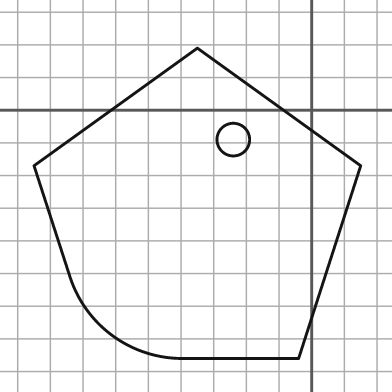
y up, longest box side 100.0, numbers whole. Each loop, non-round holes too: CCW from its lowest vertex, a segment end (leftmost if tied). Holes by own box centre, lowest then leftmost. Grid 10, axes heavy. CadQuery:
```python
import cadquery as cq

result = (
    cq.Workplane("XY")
    .moveTo(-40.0, -76.0)
    .lineTo(-4.0, -76.0)
    .lineTo(15.0, -17.0)
    .lineTo(-35.0, 19.0)
    .lineTo(-85.0, -17.0)
    .lineTo(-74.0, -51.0)
    .threePointArc((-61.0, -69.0), (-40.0, -76.0))
    .close()
    .moveTo(-24.0, -9.0)
    .circle(5.0)
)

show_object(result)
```